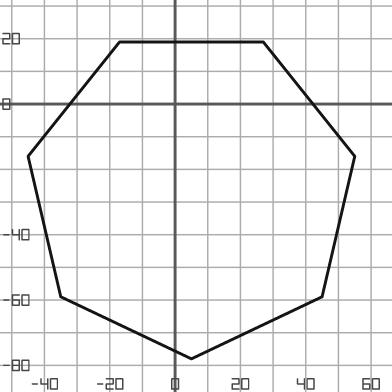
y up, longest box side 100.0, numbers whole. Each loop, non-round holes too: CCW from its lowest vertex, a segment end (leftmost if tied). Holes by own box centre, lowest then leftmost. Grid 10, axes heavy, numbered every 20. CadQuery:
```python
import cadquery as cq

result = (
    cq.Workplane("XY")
    .moveTo(5.0, -78.0)
    .lineTo(45.0, -59.0)
    .lineTo(55.0, -16.0)
    .lineTo(27.0, 19.0)
    .lineTo(-17.0, 19.0)
    .lineTo(-45.0, -16.0)
    .lineTo(-35.0, -59.0)
    .close()
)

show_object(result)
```